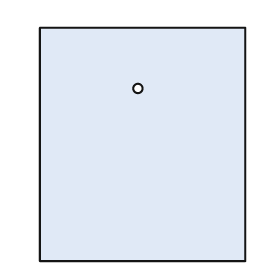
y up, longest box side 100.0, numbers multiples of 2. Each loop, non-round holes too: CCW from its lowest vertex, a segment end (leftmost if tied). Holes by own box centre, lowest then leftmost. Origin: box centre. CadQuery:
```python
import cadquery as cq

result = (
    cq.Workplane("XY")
    .moveTo(-44.0, -50.0)
    .lineTo(44.0, -50.0)
    .lineTo(44.0, 50.0)
    .lineTo(-44.0, 50.0)
    .close()
    .moveTo(-2.0, 24.0)
    .circle(2.0)
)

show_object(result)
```